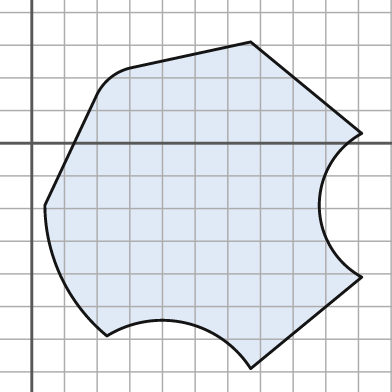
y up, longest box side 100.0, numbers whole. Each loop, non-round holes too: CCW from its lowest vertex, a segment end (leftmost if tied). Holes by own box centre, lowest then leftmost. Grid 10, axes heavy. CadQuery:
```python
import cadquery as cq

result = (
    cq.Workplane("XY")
    .moveTo(67.0, -69.0)
    .lineTo(101.0, -41.0)
    .threePointArc((88.0, -19.0), (101.0, 3.0))
    .lineTo(67.0, 31.0)
    .lineTo(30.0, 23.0)
    .threePointArc((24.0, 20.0), (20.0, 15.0))
    .lineTo(4.0, -19.0)
    .threePointArc((9.0, -41.0), (23.0, -59.0))
    .threePointArc((47.0, -55.0), (67.0, -69.0))
    .close()
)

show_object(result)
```